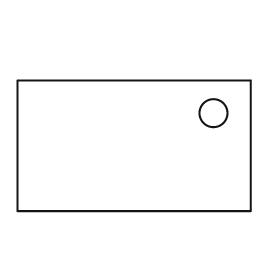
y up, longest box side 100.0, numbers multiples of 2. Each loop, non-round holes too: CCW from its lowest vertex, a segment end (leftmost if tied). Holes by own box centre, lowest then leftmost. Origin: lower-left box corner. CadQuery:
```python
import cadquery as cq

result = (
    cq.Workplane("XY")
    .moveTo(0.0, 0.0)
    .lineTo(100.0, 0.0)
    .lineTo(100.0, 56.0)
    .lineTo(0.0, 56.0)
    .close()
    .moveTo(84.0, 42.0)
    .circle(6.0)
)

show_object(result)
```